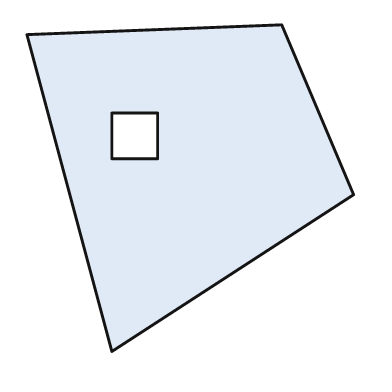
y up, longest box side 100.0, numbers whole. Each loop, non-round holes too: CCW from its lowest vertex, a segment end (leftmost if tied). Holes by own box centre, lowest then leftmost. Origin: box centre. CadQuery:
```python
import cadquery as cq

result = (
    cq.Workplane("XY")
    .moveTo(-24.0, -50.0)
    .lineTo(50.0, -2.0)
    .lineTo(28.0, 50.0)
    .lineTo(-50.0, 47.0)
    .close()
    .moveTo(-24.0, 9.0)
    .lineTo(-10.0, 9.0)
    .lineTo(-10.0, 23.0)
    .lineTo(-24.0, 23.0)
    .close()
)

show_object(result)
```